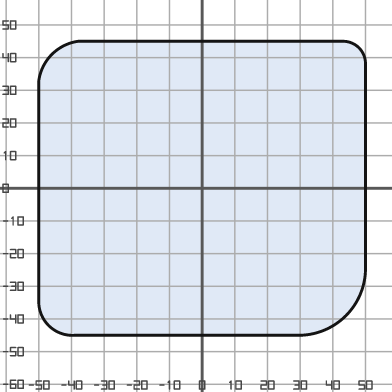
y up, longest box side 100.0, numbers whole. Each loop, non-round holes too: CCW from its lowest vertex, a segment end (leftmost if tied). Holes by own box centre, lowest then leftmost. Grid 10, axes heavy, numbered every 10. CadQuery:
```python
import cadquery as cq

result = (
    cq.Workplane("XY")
    .moveTo(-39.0, -45.0)
    .lineTo(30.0, -45.0)
    .threePointArc((44.0, -39.0), (50.0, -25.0))
    .lineTo(50.0, 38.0)
    .threePointArc((48.0, 43.0), (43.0, 45.0))
    .lineTo(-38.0, 45.0)
    .threePointArc((-46.0, 41.0), (-50.0, 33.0))
    .lineTo(-50.0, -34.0)
    .threePointArc((-47.0, -42.0), (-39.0, -45.0))
    .close()
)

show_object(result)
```